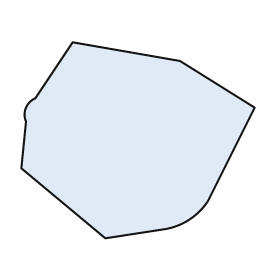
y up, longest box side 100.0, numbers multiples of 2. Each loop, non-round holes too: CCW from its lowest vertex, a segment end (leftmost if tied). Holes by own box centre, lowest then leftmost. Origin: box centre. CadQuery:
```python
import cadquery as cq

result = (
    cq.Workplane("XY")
    .moveTo(-14.0, -42.0)
    .lineTo(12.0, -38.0)
    .threePointArc((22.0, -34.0), (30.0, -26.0))
    .lineTo(50.0, 14.0)
    .lineTo(18.0, 34.0)
    .lineTo(-28.0, 42.0)
    .lineTo(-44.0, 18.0)
    .threePointArc((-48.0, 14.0), (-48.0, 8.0))
    .lineTo(-50.0, -12.0)
    .close()
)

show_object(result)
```